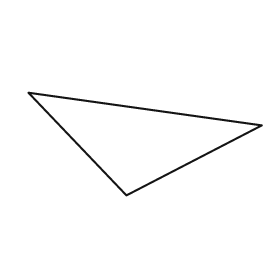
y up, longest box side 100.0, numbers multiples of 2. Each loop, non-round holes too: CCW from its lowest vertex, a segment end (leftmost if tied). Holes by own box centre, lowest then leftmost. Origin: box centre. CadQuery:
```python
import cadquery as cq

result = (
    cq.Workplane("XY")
    .moveTo(-8.0, -22.0)
    .lineTo(50.0, 8.0)
    .lineTo(-50.0, 22.0)
    .close()
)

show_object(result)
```